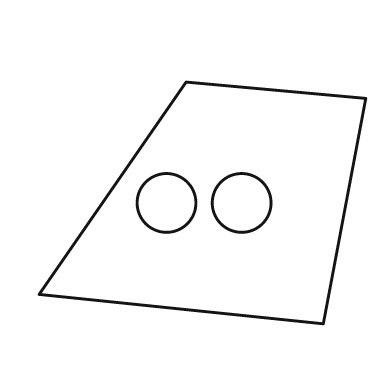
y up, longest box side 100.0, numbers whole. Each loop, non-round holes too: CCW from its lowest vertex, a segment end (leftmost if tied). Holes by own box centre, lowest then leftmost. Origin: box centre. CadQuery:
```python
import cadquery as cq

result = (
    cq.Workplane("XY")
    .moveTo(37.0, -37.0)
    .lineTo(50.0, 32.0)
    .lineTo(-5.0, 37.0)
    .lineTo(-50.0, -28.0)
    .close()
    .moveTo(-11.0, 0.0)
    .circle(9.0)
    .moveTo(12.0, 0.0)
    .circle(9.0)
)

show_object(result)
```